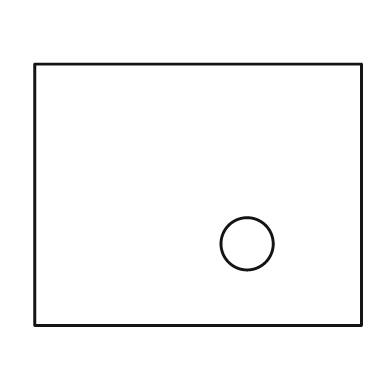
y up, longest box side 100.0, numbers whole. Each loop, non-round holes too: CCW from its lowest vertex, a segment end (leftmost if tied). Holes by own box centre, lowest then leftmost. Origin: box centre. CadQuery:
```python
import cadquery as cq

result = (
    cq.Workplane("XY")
    .moveTo(-50.0, -40.0)
    .lineTo(50.0, -40.0)
    .lineTo(50.0, 40.0)
    .lineTo(-50.0, 40.0)
    .close()
    .moveTo(15.0, -15.0)
    .circle(8.0)
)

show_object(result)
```